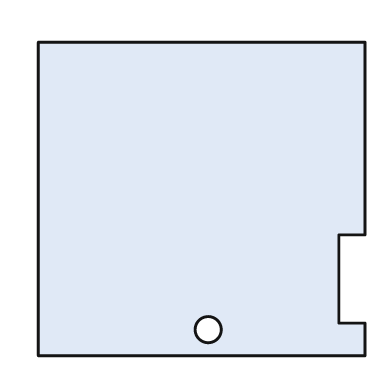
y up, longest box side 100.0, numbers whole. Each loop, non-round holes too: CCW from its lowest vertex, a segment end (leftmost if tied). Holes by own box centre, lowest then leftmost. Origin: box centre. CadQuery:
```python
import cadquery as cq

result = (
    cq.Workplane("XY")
    .moveTo(-50.0, -48.0)
    .lineTo(50.0, -48.0)
    .lineTo(50.0, -38.0)
    .lineTo(42.0, -38.0)
    .lineTo(42.0, -11.0)
    .lineTo(50.0, -11.0)
    .lineTo(50.0, 48.0)
    .lineTo(-50.0, 48.0)
    .close()
    .moveTo(2.0, -40.0)
    .circle(4.0)
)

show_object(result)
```